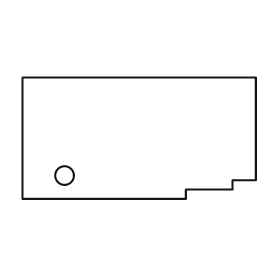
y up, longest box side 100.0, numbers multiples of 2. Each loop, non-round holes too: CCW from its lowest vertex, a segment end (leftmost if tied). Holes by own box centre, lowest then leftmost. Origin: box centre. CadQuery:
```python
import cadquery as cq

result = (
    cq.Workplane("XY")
    .moveTo(-50.0, -26.0)
    .lineTo(20.0, -26.0)
    .lineTo(20.0, -22.0)
    .lineTo(40.0, -22.0)
    .lineTo(40.0, -18.0)
    .lineTo(50.0, -18.0)
    .lineTo(50.0, 26.0)
    .lineTo(-50.0, 26.0)
    .close()
    .moveTo(-32.0, -16.0)
    .circle(4.0)
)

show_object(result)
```